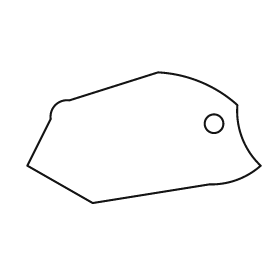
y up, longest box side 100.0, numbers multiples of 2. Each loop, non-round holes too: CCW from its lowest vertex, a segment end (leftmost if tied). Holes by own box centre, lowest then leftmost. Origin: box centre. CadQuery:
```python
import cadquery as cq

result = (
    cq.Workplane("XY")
    .moveTo(-22.0, -28.0)
    .lineTo(28.0, -20.0)
    .threePointArc((40.0, -18.0), (50.0, -12.0))
    .threePointArc((42.0, 0.0), (40.0, 14.0))
    .threePointArc((24.0, 24.0), (6.0, 28.0))
    .lineTo(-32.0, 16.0)
    .threePointArc((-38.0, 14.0), (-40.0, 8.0))
    .lineTo(-50.0, -12.0)
    .close()
    .moveTo(30.0, 6.0)
    .circle(4.0)
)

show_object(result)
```